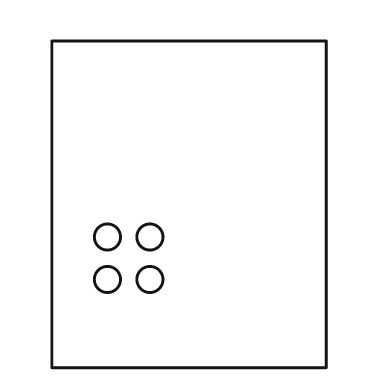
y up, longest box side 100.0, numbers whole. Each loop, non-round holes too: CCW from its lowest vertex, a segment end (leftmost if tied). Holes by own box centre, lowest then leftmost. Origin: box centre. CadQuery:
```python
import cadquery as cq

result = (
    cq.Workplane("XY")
    .moveTo(-42.0, -50.0)
    .lineTo(42.0, -50.0)
    .lineTo(42.0, 50.0)
    .lineTo(-42.0, 50.0)
    .close()
    .moveTo(-25.0, -23.0)
    .circle(4.0)
    .moveTo(-12.0, -23.0)
    .circle(4.0)
    .moveTo(-25.0, -10.0)
    .circle(4.0)
    .moveTo(-12.0, -10.0)
    .circle(4.0)
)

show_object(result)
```